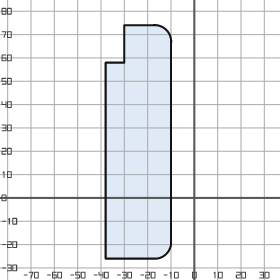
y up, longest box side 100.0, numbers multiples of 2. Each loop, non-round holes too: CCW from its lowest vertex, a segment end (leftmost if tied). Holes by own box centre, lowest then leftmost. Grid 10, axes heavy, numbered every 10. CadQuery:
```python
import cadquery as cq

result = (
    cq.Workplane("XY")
    .moveTo(-38.0, -26.0)
    .lineTo(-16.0, -26.0)
    .threePointArc((-12.0, -24.0), (-10.0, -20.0))
    .lineTo(-10.0, 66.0)
    .threePointArc((-12.0, 72.0), (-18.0, 74.0))
    .lineTo(-30.0, 74.0)
    .lineTo(-30.0, 58.0)
    .lineTo(-38.0, 58.0)
    .close()
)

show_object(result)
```